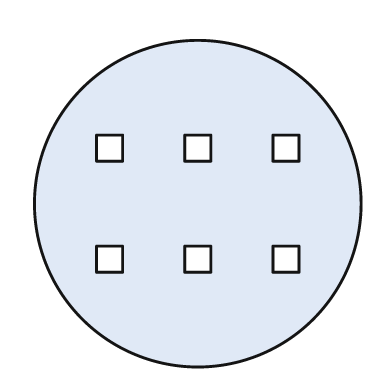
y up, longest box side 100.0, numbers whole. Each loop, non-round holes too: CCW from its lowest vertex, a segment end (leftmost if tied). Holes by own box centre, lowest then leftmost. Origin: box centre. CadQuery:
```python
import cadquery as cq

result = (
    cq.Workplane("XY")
    .moveTo(0.0, 0.0)
    .circle(50.0)
    .moveTo(-31.0, -21.0)
    .lineTo(-23.0, -21.0)
    .lineTo(-23.0, -13.0)
    .lineTo(-31.0, -13.0)
    .close()
    .moveTo(-4.0, -21.0)
    .lineTo(4.0, -21.0)
    .lineTo(4.0, -13.0)
    .lineTo(-4.0, -13.0)
    .close()
    .moveTo(23.0, -21.0)
    .lineTo(31.0, -21.0)
    .lineTo(31.0, -13.0)
    .lineTo(23.0, -13.0)
    .close()
    .moveTo(-31.0, 13.0)
    .lineTo(-23.0, 13.0)
    .lineTo(-23.0, 21.0)
    .lineTo(-31.0, 21.0)
    .close()
    .moveTo(-4.0, 13.0)
    .lineTo(4.0, 13.0)
    .lineTo(4.0, 21.0)
    .lineTo(-4.0, 21.0)
    .close()
    .moveTo(23.0, 13.0)
    .lineTo(31.0, 13.0)
    .lineTo(31.0, 21.0)
    .lineTo(23.0, 21.0)
    .close()
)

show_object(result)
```